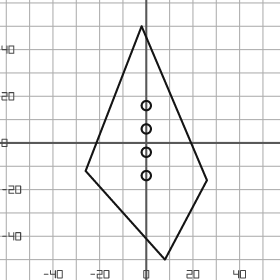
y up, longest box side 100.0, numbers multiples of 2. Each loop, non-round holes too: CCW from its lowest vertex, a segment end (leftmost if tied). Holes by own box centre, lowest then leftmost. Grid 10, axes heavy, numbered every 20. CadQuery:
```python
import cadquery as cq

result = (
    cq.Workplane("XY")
    .moveTo(8.0, -50.0)
    .lineTo(26.0, -16.0)
    .lineTo(-2.0, 50.0)
    .lineTo(-26.0, -12.0)
    .close()
    .moveTo(0.0, -14.0)
    .circle(2.0)
    .moveTo(0.0, -4.0)
    .circle(2.0)
    .moveTo(0.0, 6.0)
    .circle(2.0)
    .moveTo(0.0, 16.0)
    .circle(2.0)
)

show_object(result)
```